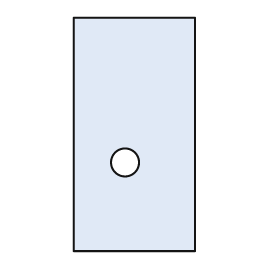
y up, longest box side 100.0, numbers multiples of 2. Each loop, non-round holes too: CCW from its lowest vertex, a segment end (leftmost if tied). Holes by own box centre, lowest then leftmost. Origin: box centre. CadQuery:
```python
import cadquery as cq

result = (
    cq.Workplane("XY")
    .moveTo(-26.0, -50.0)
    .lineTo(26.0, -50.0)
    .lineTo(26.0, 50.0)
    .lineTo(-26.0, 50.0)
    .close()
    .moveTo(-4.0, -12.0)
    .circle(6.0)
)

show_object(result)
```